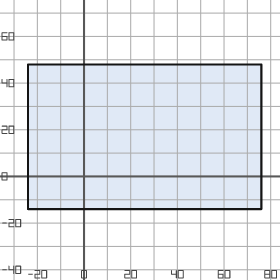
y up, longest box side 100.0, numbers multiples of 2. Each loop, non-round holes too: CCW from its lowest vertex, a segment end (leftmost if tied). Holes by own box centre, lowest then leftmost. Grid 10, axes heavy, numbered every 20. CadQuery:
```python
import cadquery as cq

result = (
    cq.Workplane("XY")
    .moveTo(-24.0, -14.0)
    .lineTo(76.0, -14.0)
    .lineTo(76.0, 48.0)
    .lineTo(-24.0, 48.0)
    .close()
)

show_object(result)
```